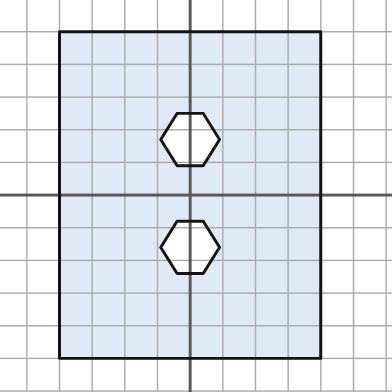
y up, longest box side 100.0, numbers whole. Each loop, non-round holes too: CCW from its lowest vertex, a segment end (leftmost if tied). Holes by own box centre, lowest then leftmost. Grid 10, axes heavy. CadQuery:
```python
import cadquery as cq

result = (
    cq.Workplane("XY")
    .moveTo(-40.0, -50.0)
    .lineTo(40.0, -50.0)
    .lineTo(40.0, 50.0)
    .lineTo(-40.0, 50.0)
    .close()
    .moveTo(-4.0, -24.0)
    .lineTo(4.0, -24.0)
    .lineTo(9.0, -16.0)
    .lineTo(4.0, -8.0)
    .lineTo(-4.0, -8.0)
    .lineTo(-9.0, -16.0)
    .close()
    .moveTo(-4.0, 9.0)
    .lineTo(4.0, 9.0)
    .lineTo(9.0, 17.0)
    .lineTo(4.0, 25.0)
    .lineTo(-4.0, 25.0)
    .lineTo(-9.0, 17.0)
    .close()
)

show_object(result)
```